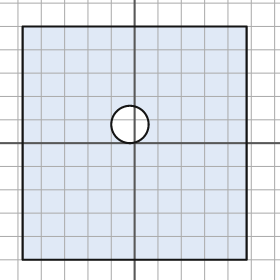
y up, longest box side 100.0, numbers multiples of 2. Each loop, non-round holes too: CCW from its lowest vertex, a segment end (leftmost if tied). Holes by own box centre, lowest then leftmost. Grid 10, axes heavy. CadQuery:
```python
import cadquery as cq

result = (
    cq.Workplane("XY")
    .moveTo(-48.0, -50.0)
    .lineTo(48.0, -50.0)
    .lineTo(48.0, 50.0)
    .lineTo(-48.0, 50.0)
    .close()
    .moveTo(-2.0, 8.0)
    .circle(8.0)
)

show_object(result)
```